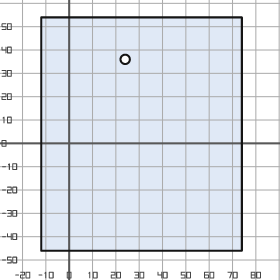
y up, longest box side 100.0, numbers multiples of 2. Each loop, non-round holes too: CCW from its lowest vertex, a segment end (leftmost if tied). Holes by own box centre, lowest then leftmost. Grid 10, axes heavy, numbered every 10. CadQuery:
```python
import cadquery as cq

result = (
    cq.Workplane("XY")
    .moveTo(-12.0, -46.0)
    .lineTo(74.0, -46.0)
    .lineTo(74.0, 54.0)
    .lineTo(-12.0, 54.0)
    .close()
    .moveTo(24.0, 36.0)
    .circle(2.0)
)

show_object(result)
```